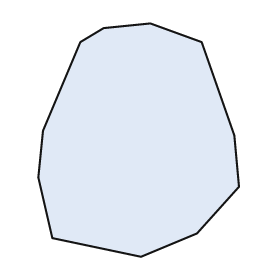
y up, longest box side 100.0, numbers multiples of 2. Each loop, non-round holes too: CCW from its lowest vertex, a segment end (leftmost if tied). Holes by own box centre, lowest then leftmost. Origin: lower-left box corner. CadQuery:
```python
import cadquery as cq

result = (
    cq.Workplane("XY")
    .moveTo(44.0, 0.0)
    .lineTo(68.0, 10.0)
    .lineTo(86.0, 30.0)
    .lineTo(84.0, 52.0)
    .lineTo(70.0, 92.0)
    .lineTo(48.0, 100.0)
    .lineTo(28.0, 98.0)
    .lineTo(18.0, 92.0)
    .lineTo(2.0, 54.0)
    .lineTo(0.0, 34.0)
    .lineTo(6.0, 8.0)
    .close()
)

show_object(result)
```